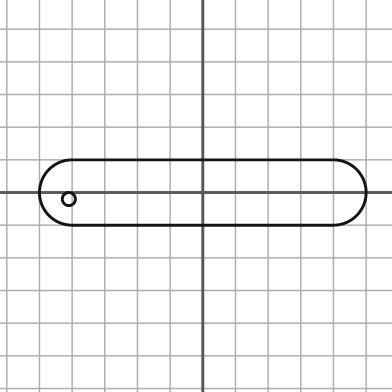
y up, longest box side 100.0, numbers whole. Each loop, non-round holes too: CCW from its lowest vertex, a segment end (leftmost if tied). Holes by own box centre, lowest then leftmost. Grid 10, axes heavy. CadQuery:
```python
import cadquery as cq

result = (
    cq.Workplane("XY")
    .moveTo(-40.0, -10.0)
    .lineTo(40.0, -10.0)
    .threePointArc((50.0, 0.0), (40.0, 10.0))
    .lineTo(-40.0, 10.0)
    .threePointArc((-50.0, 0.0), (-40.0, -10.0))
    .close()
    .moveTo(-41.0, -2.0)
    .circle(2.0)
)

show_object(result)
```